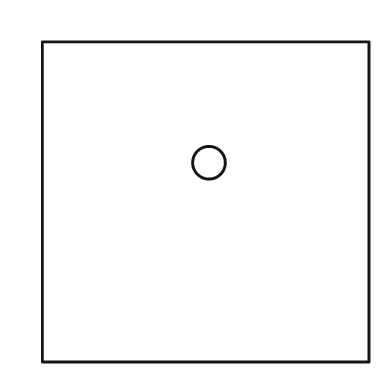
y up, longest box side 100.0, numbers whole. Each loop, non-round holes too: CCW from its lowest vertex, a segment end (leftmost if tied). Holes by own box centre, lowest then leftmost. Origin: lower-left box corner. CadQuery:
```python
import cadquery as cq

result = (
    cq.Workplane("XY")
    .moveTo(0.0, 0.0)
    .lineTo(100.0, 0.0)
    .lineTo(100.0, 98.0)
    .lineTo(0.0, 98.0)
    .close()
    .moveTo(51.0, 61.0)
    .circle(5.0)
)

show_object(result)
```